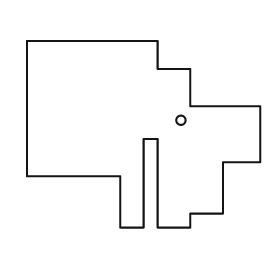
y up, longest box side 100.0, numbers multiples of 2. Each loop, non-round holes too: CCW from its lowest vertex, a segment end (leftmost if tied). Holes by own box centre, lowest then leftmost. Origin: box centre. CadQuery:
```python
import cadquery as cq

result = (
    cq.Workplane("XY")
    .moveTo(-10.0, -40.0)
    .lineTo(0.0, -40.0)
    .lineTo(0.0, -2.0)
    .lineTo(6.0, -2.0)
    .lineTo(6.0, -40.0)
    .lineTo(20.0, -40.0)
    .lineTo(20.0, -34.0)
    .lineTo(34.0, -34.0)
    .lineTo(34.0, -12.0)
    .lineTo(50.0, -12.0)
    .lineTo(50.0, 12.0)
    .lineTo(20.0, 12.0)
    .lineTo(20.0, 28.0)
    .lineTo(6.0, 28.0)
    .lineTo(6.0, 40.0)
    .lineTo(-50.0, 40.0)
    .lineTo(-50.0, -18.0)
    .lineTo(-10.0, -18.0)
    .close()
    .moveTo(16.0, 6.0)
    .circle(2.0)
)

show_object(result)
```